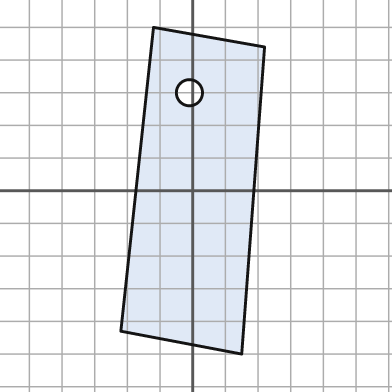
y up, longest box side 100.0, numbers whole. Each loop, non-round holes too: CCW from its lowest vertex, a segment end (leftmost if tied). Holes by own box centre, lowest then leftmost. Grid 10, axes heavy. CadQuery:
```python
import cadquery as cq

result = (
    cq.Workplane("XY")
    .moveTo(15.0, -50.0)
    .lineTo(22.0, 44.0)
    .lineTo(-12.0, 50.0)
    .lineTo(-22.0, -43.0)
    .close()
    .moveTo(-1.0, 30.0)
    .circle(4.0)
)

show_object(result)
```